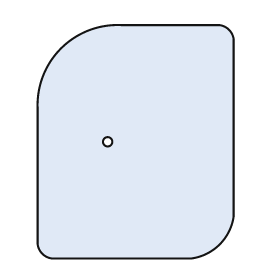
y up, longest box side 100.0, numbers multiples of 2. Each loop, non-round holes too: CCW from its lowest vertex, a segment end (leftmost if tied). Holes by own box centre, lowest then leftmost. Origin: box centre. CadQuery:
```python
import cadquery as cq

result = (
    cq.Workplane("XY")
    .moveTo(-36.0, -50.0)
    .lineTo(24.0, -50.0)
    .threePointArc((36.0, -44.0), (42.0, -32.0))
    .lineTo(42.0, 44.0)
    .threePointArc((40.0, 48.0), (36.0, 50.0))
    .lineTo(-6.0, 50.0)
    .threePointArc((-32.0, 40.0), (-42.0, 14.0))
    .lineTo(-42.0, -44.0)
    .threePointArc((-40.0, -48.0), (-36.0, -50.0))
    .close()
    .moveTo(-12.0, 0.0)
    .circle(2.0)
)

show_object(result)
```